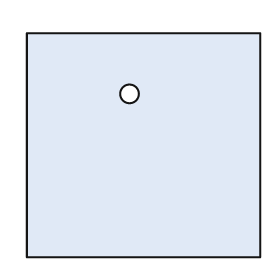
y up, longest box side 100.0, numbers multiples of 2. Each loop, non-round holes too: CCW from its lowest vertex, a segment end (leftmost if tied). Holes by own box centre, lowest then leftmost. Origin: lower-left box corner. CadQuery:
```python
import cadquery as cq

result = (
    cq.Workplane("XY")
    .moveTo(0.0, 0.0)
    .lineTo(100.0, 0.0)
    .lineTo(100.0, 96.0)
    .lineTo(0.0, 96.0)
    .close()
    .moveTo(44.0, 70.0)
    .circle(4.0)
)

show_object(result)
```